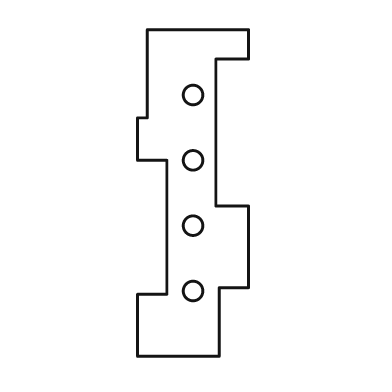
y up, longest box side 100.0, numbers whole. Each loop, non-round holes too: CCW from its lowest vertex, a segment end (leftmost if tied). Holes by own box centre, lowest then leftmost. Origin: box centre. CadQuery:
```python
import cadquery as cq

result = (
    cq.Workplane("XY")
    .moveTo(-17.0, -50.0)
    .lineTo(8.0, -50.0)
    .lineTo(8.0, -29.0)
    .lineTo(17.0, -29.0)
    .lineTo(17.0, -4.0)
    .lineTo(7.0, -4.0)
    .lineTo(7.0, 41.0)
    .lineTo(17.0, 41.0)
    .lineTo(17.0, 50.0)
    .lineTo(-14.0, 50.0)
    .lineTo(-14.0, 23.0)
    .lineTo(-17.0, 23.0)
    .lineTo(-17.0, 10.0)
    .lineTo(-8.0, 10.0)
    .lineTo(-8.0, -31.0)
    .lineTo(-17.0, -31.0)
    .close()
    .moveTo(0.0, -30.0)
    .circle(3.0)
    .moveTo(0.0, -10.0)
    .circle(3.0)
    .moveTo(0.0, 10.0)
    .circle(3.0)
    .moveTo(0.0, 30.0)
    .circle(3.0)
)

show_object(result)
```